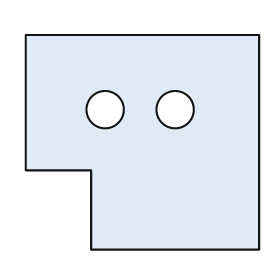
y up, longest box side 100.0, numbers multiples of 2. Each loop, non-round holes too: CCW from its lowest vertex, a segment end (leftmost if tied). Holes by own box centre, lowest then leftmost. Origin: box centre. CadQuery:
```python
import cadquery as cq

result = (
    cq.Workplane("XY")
    .moveTo(-22.0, -46.0)
    .lineTo(50.0, -46.0)
    .lineTo(50.0, 46.0)
    .lineTo(-50.0, 46.0)
    .lineTo(-50.0, -12.0)
    .lineTo(-22.0, -12.0)
    .close()
    .moveTo(-16.0, 14.0)
    .circle(8.0)
    .moveTo(14.0, 14.0)
    .circle(8.0)
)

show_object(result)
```